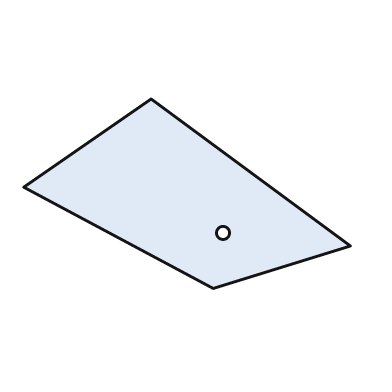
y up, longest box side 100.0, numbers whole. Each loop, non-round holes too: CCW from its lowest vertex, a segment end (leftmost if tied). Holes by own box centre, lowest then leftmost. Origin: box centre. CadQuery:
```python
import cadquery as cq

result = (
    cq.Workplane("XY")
    .moveTo(8.0, -29.0)
    .lineTo(50.0, -16.0)
    .lineTo(-11.0, 29.0)
    .lineTo(-50.0, 2.0)
    .close()
    .moveTo(11.0, -12.0)
    .circle(2.0)
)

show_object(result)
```